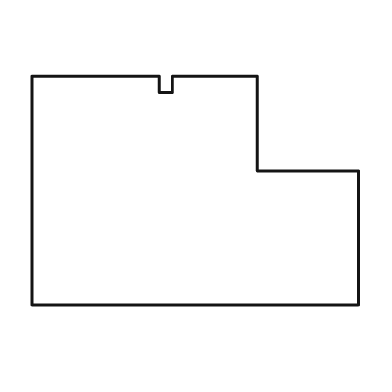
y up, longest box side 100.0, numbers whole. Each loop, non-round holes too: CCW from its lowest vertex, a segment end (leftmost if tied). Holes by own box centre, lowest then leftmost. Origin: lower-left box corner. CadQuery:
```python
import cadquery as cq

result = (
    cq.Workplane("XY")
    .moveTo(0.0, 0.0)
    .lineTo(100.0, 0.0)
    .lineTo(100.0, 41.0)
    .lineTo(69.0, 41.0)
    .lineTo(69.0, 70.0)
    .lineTo(43.0, 70.0)
    .lineTo(43.0, 65.0)
    .lineTo(39.0, 65.0)
    .lineTo(39.0, 70.0)
    .lineTo(0.0, 70.0)
    .close()
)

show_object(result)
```